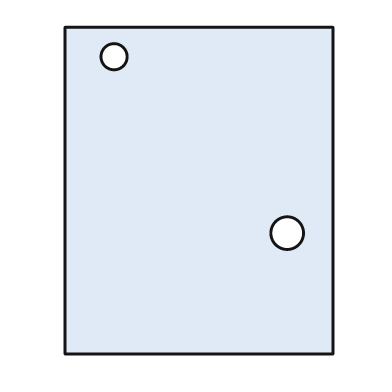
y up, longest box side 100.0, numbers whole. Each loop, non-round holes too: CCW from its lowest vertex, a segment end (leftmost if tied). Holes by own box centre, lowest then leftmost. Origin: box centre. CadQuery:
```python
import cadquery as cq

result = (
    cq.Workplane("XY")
    .moveTo(-41.0, -50.0)
    .lineTo(41.0, -50.0)
    .lineTo(41.0, 50.0)
    .lineTo(-41.0, 50.0)
    .close()
    .moveTo(27.0, -13.0)
    .circle(5.0)
    .moveTo(-26.0, 41.0)
    .circle(4.0)
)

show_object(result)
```